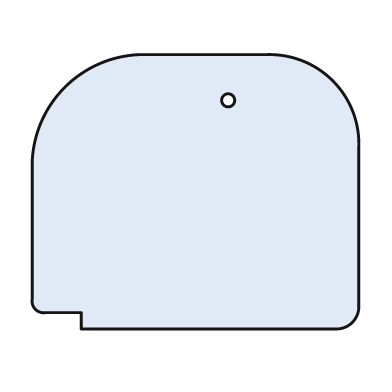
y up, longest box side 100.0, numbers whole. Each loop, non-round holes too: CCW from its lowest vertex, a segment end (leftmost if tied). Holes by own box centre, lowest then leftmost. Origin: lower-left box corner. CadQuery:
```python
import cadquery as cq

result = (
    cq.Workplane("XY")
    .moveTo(15.0, 0.0)
    .lineTo(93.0, 0.0)
    .threePointArc((98.0, 2.0), (100.0, 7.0))
    .lineTo(100.0, 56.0)
    .threePointArc((92.0, 76.0), (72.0, 84.0))
    .lineTo(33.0, 84.0)
    .threePointArc((10.0, 74.0), (0.0, 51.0))
    .lineTo(0.0, 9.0)
    .threePointArc((1.0, 6.0), (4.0, 5.0))
    .lineTo(15.0, 5.0)
    .close()
    .moveTo(60.0, 70.0)
    .circle(2.0)
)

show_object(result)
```